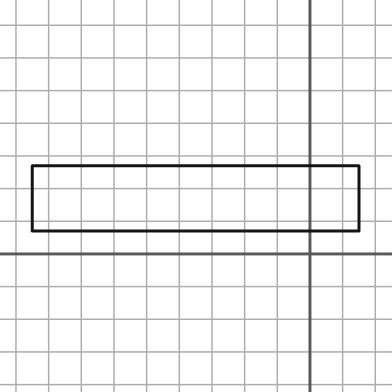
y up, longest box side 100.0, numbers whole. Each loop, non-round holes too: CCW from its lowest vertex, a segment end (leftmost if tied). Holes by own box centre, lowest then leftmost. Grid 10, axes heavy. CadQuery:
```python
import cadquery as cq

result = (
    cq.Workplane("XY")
    .moveTo(-85.0, 7.0)
    .lineTo(15.0, 7.0)
    .lineTo(15.0, 27.0)
    .lineTo(-85.0, 27.0)
    .close()
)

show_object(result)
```